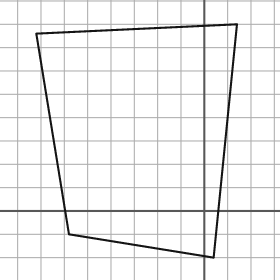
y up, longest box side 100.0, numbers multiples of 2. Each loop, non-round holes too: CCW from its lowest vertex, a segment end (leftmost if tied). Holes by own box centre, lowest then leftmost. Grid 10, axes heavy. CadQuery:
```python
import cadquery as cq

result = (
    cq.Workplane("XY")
    .moveTo(4.0, -20.0)
    .lineTo(14.0, 80.0)
    .lineTo(-72.0, 76.0)
    .lineTo(-58.0, -10.0)
    .close()
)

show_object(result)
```